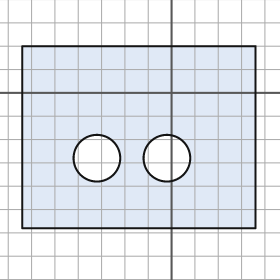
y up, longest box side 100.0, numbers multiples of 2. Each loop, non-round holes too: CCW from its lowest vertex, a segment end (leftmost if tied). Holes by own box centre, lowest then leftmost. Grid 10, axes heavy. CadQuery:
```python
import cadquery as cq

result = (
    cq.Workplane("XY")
    .moveTo(-64.0, -58.0)
    .lineTo(36.0, -58.0)
    .lineTo(36.0, 20.0)
    .lineTo(-64.0, 20.0)
    .close()
    .moveTo(-32.0, -28.0)
    .circle(10.0)
    .moveTo(-2.0, -28.0)
    .circle(10.0)
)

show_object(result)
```